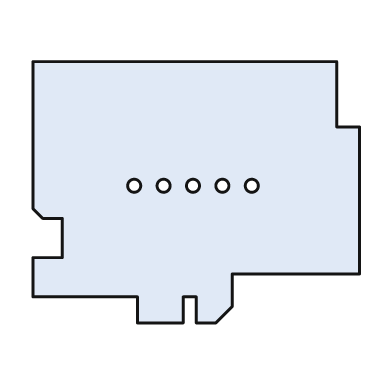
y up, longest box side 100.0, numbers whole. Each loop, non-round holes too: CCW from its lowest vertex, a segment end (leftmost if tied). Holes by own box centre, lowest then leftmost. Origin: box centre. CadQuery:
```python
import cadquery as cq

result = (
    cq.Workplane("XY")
    .moveTo(-18.0, -40.0)
    .lineTo(-4.0, -40.0)
    .lineTo(-4.0, -32.0)
    .lineTo(0.0, -32.0)
    .lineTo(0.0, -40.0)
    .lineTo(6.0, -40.0)
    .lineTo(11.0, -35.0)
    .lineTo(11.0, -25.0)
    .lineTo(50.0, -25.0)
    .lineTo(50.0, 20.0)
    .lineTo(43.0, 20.0)
    .lineTo(43.0, 40.0)
    .lineTo(-50.0, 40.0)
    .lineTo(-50.0, -5.0)
    .lineTo(-47.0, -8.0)
    .lineTo(-41.0, -8.0)
    .lineTo(-41.0, -20.0)
    .lineTo(-50.0, -20.0)
    .lineTo(-50.0, -32.0)
    .lineTo(-18.0, -32.0)
    .close()
    .moveTo(-19.0, 2.0)
    .circle(2.0)
    .moveTo(-10.0, 2.0)
    .circle(2.0)
    .moveTo(-1.0, 2.0)
    .circle(2.0)
    .moveTo(8.0, 2.0)
    .circle(2.0)
    .moveTo(17.0, 2.0)
    .circle(2.0)
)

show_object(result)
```